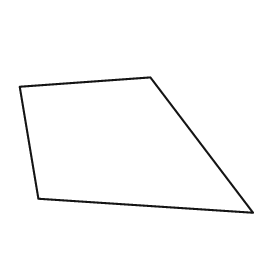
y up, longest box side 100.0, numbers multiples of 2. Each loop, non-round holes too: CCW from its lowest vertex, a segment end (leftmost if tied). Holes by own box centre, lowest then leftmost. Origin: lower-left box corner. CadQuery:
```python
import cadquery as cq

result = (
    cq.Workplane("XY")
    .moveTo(100.0, 0.0)
    .lineTo(56.0, 58.0)
    .lineTo(0.0, 54.0)
    .lineTo(8.0, 6.0)
    .close()
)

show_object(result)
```